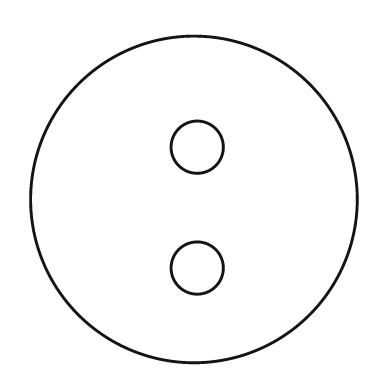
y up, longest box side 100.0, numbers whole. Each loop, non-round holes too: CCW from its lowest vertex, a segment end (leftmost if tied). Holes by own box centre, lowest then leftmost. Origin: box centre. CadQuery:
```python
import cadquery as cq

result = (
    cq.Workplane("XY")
    .moveTo(0.0, 0.0)
    .circle(50.0)
    .moveTo(1.0, -21.0)
    .circle(8.0)
    .moveTo(1.0, 16.0)
    .circle(8.0)
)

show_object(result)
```